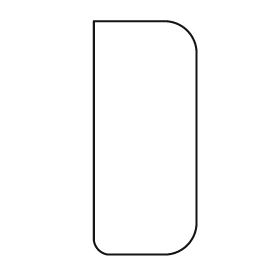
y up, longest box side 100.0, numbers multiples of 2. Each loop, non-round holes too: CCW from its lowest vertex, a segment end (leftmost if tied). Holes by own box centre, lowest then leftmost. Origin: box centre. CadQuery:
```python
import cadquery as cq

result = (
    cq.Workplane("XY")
    .moveTo(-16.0, -50.0)
    .lineTo(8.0, -50.0)
    .threePointArc((18.0, -46.0), (22.0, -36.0))
    .lineTo(22.0, 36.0)
    .threePointArc((18.0, 46.0), (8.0, 50.0))
    .lineTo(-22.0, 50.0)
    .lineTo(-22.0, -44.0)
    .threePointArc((-20.0, -48.0), (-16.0, -50.0))
    .close()
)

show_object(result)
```